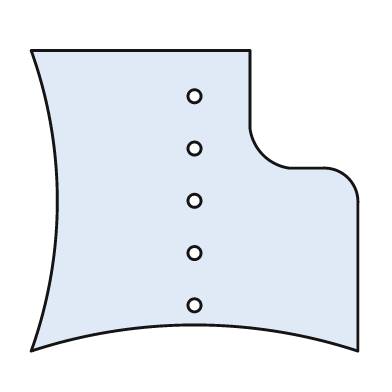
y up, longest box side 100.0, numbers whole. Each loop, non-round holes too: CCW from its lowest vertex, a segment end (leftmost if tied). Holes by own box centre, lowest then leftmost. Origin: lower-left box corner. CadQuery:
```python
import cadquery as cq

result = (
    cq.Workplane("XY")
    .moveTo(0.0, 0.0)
    .threePointArc((50.0, 8.0), (100.0, 0.0))
    .lineTo(100.0, 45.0)
    .threePointArc((97.0, 53.0), (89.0, 56.0))
    .lineTo(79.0, 56.0)
    .threePointArc((71.0, 60.0), (67.0, 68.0))
    .lineTo(67.0, 92.0)
    .lineTo(0.0, 92.0)
    .threePointArc((8.0, 46.0), (0.0, 0.0))
    .close()
    .moveTo(50.0, 14.0)
    .circle(2.0)
    .moveTo(50.0, 30.0)
    .circle(2.0)
    .moveTo(50.0, 46.0)
    .circle(2.0)
    .moveTo(50.0, 62.0)
    .circle(2.0)
    .moveTo(50.0, 78.0)
    .circle(2.0)
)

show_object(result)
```